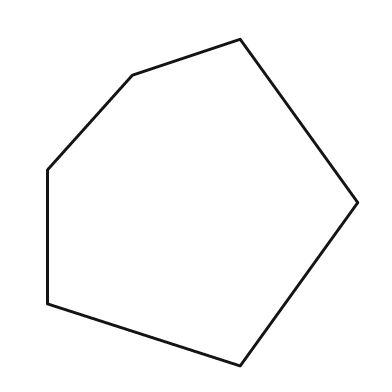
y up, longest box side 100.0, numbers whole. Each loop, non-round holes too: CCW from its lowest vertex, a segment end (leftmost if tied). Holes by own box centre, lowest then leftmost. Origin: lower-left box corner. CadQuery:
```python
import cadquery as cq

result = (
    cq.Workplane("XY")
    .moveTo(59.0, 0.0)
    .lineTo(95.0, 50.0)
    .lineTo(59.0, 100.0)
    .lineTo(26.0, 89.0)
    .lineTo(0.0, 60.0)
    .lineTo(0.0, 19.0)
    .close()
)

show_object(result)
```